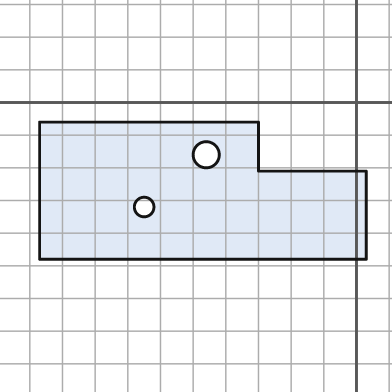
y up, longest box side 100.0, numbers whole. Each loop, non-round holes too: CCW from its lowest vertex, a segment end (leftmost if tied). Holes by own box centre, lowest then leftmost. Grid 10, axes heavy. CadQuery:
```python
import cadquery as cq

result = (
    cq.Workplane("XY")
    .moveTo(-97.0, -48.0)
    .lineTo(3.0, -48.0)
    .lineTo(3.0, -21.0)
    .lineTo(-30.0, -21.0)
    .lineTo(-30.0, -6.0)
    .lineTo(-97.0, -6.0)
    .close()
    .moveTo(-65.0, -32.0)
    .circle(3.0)
    .moveTo(-46.0, -16.0)
    .circle(4.0)
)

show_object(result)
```